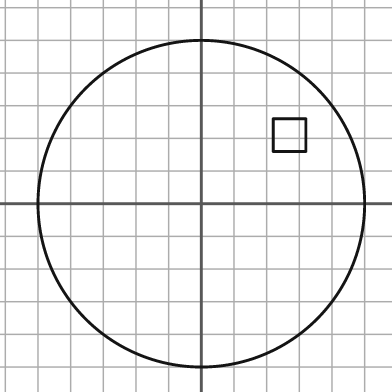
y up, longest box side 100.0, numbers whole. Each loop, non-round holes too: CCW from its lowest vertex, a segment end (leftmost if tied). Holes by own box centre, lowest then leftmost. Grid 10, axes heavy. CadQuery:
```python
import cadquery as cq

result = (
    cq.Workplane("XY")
    .moveTo(0.0, 0.0)
    .circle(50.0)
    .moveTo(22.0, 16.0)
    .lineTo(32.0, 16.0)
    .lineTo(32.0, 26.0)
    .lineTo(22.0, 26.0)
    .close()
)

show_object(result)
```